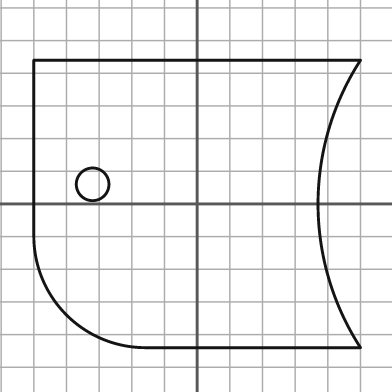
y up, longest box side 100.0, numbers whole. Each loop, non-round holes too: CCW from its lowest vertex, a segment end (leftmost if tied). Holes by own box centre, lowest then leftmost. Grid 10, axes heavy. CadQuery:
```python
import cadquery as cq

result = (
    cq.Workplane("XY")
    .moveTo(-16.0, -44.0)
    .lineTo(50.0, -44.0)
    .threePointArc((37.0, 0.0), (50.0, 44.0))
    .lineTo(-50.0, 44.0)
    .lineTo(-50.0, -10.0)
    .threePointArc((-40.0, -34.0), (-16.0, -44.0))
    .close()
    .moveTo(-32.0, 6.0)
    .circle(5.0)
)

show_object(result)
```